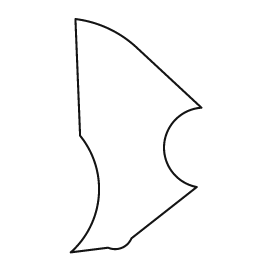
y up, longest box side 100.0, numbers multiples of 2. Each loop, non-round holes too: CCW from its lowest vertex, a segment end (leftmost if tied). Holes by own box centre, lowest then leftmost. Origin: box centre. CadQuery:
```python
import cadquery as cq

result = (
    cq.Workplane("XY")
    .moveTo(-28.0, -50.0)
    .lineTo(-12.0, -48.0)
    .threePointArc((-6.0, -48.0), (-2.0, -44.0))
    .lineTo(26.0, -22.0)
    .threePointArc((12.0, -4.0), (28.0, 12.0))
    .lineTo(0.0, 38.0)
    .threePointArc((-12.0, 46.0), (-26.0, 50.0))
    .lineTo(-24.0, 0.0)
    .threePointArc((-16.0, -26.0), (-28.0, -50.0))
    .close()
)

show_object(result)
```